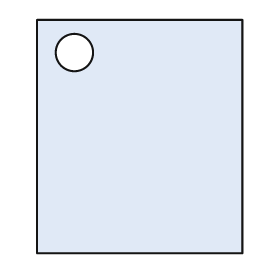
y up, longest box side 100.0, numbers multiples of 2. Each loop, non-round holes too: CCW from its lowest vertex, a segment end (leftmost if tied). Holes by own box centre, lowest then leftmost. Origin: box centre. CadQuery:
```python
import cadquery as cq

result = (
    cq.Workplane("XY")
    .moveTo(-44.0, -50.0)
    .lineTo(44.0, -50.0)
    .lineTo(44.0, 50.0)
    .lineTo(-44.0, 50.0)
    .close()
    .moveTo(-28.0, 36.0)
    .circle(8.0)
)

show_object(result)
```